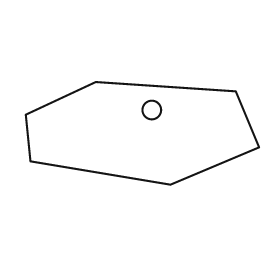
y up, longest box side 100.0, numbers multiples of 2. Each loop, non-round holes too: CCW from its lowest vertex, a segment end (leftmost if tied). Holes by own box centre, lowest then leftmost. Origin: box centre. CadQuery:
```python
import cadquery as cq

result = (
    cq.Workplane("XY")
    .moveTo(12.0, -22.0)
    .lineTo(50.0, -6.0)
    .lineTo(40.0, 18.0)
    .lineTo(-20.0, 22.0)
    .lineTo(-50.0, 8.0)
    .lineTo(-48.0, -12.0)
    .close()
    .moveTo(4.0, 10.0)
    .circle(4.0)
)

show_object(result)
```